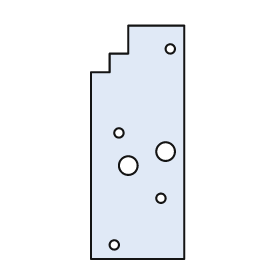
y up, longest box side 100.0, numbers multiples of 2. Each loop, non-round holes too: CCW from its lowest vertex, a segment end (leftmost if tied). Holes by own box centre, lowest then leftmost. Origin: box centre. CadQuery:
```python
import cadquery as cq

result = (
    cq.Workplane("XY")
    .moveTo(-20.0, -50.0)
    .lineTo(20.0, -50.0)
    .lineTo(20.0, 50.0)
    .lineTo(-4.0, 50.0)
    .lineTo(-4.0, 38.0)
    .lineTo(-12.0, 38.0)
    .lineTo(-12.0, 30.0)
    .lineTo(-20.0, 30.0)
    .close()
    .moveTo(-10.0, -44.0)
    .circle(2.0)
    .moveTo(10.0, -24.0)
    .circle(2.0)
    .moveTo(-4.0, -10.0)
    .circle(4.0)
    .moveTo(12.0, -4.0)
    .circle(4.0)
    .moveTo(-8.0, 4.0)
    .circle(2.0)
    .moveTo(14.0, 40.0)
    .circle(2.0)
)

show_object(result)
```